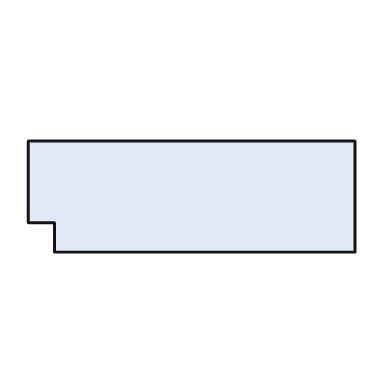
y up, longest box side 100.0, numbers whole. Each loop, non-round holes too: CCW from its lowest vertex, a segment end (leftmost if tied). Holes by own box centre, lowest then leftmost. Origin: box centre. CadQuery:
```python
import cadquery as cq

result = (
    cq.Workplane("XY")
    .moveTo(-42.0, -17.0)
    .lineTo(50.0, -17.0)
    .lineTo(50.0, 17.0)
    .lineTo(-50.0, 17.0)
    .lineTo(-50.0, -8.0)
    .lineTo(-42.0, -8.0)
    .close()
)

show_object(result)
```